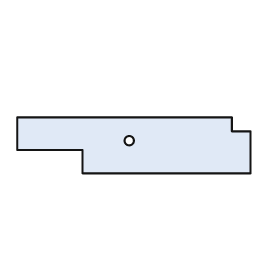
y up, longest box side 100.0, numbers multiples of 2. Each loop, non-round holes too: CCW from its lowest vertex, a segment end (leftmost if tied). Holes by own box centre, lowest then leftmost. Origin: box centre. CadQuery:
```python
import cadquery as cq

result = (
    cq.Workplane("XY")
    .moveTo(-22.0, -12.0)
    .lineTo(50.0, -12.0)
    .lineTo(50.0, 6.0)
    .lineTo(42.0, 6.0)
    .lineTo(42.0, 12.0)
    .lineTo(-50.0, 12.0)
    .lineTo(-50.0, -2.0)
    .lineTo(-22.0, -2.0)
    .close()
    .moveTo(-2.0, 2.0)
    .circle(2.0)
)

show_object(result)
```